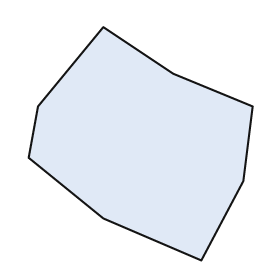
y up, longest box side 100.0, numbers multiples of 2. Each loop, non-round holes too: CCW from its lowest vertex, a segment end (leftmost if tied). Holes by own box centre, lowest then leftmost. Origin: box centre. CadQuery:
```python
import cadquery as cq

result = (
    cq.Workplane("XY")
    .moveTo(26.0, -50.0)
    .lineTo(44.0, -16.0)
    .lineTo(48.0, 16.0)
    .lineTo(14.0, 30.0)
    .lineTo(-16.0, 50.0)
    .lineTo(-44.0, 16.0)
    .lineTo(-48.0, -6.0)
    .lineTo(-16.0, -32.0)
    .close()
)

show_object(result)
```